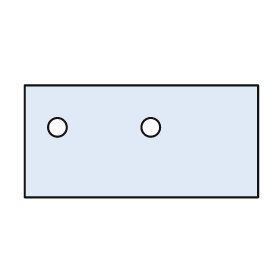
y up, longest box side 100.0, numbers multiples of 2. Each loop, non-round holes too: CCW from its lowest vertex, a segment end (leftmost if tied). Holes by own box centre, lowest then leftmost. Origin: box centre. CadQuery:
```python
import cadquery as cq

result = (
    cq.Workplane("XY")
    .moveTo(-50.0, -24.0)
    .lineTo(50.0, -24.0)
    .lineTo(50.0, 24.0)
    .lineTo(-50.0, 24.0)
    .close()
    .moveTo(-36.0, 6.0)
    .circle(4.0)
    .moveTo(4.0, 6.0)
    .circle(4.0)
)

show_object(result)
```